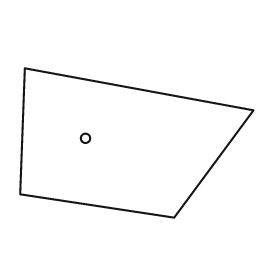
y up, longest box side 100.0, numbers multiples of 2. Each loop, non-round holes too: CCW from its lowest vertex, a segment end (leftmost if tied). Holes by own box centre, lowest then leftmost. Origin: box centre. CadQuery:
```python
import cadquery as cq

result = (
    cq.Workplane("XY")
    .moveTo(16.0, -32.0)
    .lineTo(50.0, 14.0)
    .lineTo(-48.0, 32.0)
    .lineTo(-50.0, -22.0)
    .close()
    .moveTo(-22.0, 2.0)
    .circle(2.0)
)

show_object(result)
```